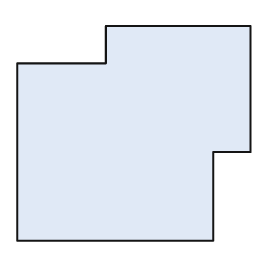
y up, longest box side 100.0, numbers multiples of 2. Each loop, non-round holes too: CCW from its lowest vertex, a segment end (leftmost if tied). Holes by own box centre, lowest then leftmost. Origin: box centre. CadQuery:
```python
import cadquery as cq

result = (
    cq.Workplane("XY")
    .moveTo(-50.0, -46.0)
    .lineTo(34.0, -46.0)
    .lineTo(34.0, -8.0)
    .lineTo(50.0, -8.0)
    .lineTo(50.0, 46.0)
    .lineTo(-12.0, 46.0)
    .lineTo(-12.0, 30.0)
    .lineTo(-50.0, 30.0)
    .close()
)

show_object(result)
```